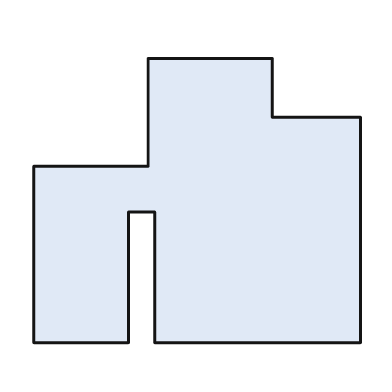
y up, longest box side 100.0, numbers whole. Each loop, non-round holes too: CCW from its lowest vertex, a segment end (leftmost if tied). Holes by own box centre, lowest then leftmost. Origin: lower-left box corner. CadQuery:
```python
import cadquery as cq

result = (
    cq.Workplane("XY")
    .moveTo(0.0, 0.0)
    .lineTo(29.0, 0.0)
    .lineTo(29.0, 40.0)
    .lineTo(37.0, 40.0)
    .lineTo(37.0, 0.0)
    .lineTo(100.0, 0.0)
    .lineTo(100.0, 69.0)
    .lineTo(73.0, 69.0)
    .lineTo(73.0, 87.0)
    .lineTo(35.0, 87.0)
    .lineTo(35.0, 54.0)
    .lineTo(0.0, 54.0)
    .close()
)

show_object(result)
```